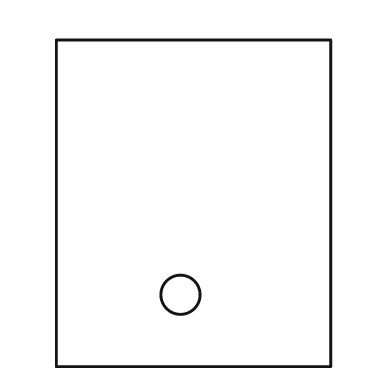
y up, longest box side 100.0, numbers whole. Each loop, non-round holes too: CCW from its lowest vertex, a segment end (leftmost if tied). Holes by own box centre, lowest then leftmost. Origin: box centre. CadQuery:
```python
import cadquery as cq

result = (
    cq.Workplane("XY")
    .moveTo(-42.0, -50.0)
    .lineTo(42.0, -50.0)
    .lineTo(42.0, 50.0)
    .lineTo(-42.0, 50.0)
    .close()
    .moveTo(-4.0, -28.0)
    .circle(6.0)
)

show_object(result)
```